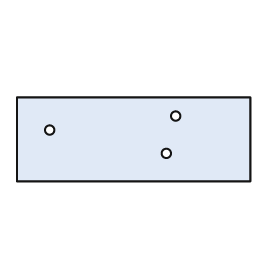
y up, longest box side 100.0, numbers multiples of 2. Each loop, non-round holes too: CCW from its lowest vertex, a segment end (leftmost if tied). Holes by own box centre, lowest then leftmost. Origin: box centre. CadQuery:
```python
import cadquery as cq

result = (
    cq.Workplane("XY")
    .moveTo(-50.0, -18.0)
    .lineTo(50.0, -18.0)
    .lineTo(50.0, 18.0)
    .lineTo(-50.0, 18.0)
    .close()
    .moveTo(14.0, -6.0)
    .circle(2.0)
    .moveTo(-36.0, 4.0)
    .circle(2.0)
    .moveTo(18.0, 10.0)
    .circle(2.0)
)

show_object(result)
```